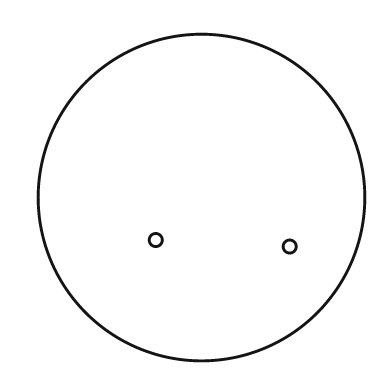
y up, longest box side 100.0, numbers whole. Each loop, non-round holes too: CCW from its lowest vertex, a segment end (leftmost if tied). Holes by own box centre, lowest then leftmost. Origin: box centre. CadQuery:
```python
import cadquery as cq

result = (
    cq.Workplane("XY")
    .moveTo(0.0, 0.0)
    .circle(50.0)
    .moveTo(27.0, -15.0)
    .circle(2.0)
    .moveTo(-14.0, -13.0)
    .circle(2.0)
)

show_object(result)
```